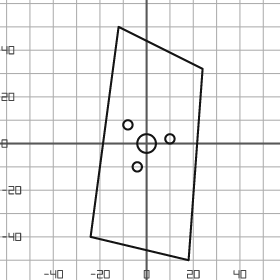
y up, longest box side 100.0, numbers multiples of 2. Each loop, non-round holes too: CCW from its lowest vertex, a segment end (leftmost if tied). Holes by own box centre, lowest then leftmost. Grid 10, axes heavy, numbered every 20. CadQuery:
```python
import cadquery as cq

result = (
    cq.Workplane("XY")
    .moveTo(18.0, -50.0)
    .lineTo(24.0, 32.0)
    .lineTo(-12.0, 50.0)
    .lineTo(-24.0, -40.0)
    .close()
    .moveTo(-4.0, -10.0)
    .circle(2.0)
    .moveTo(0.0, 0.0)
    .circle(4.0)
    .moveTo(10.0, 2.0)
    .circle(2.0)
    .moveTo(-8.0, 8.0)
    .circle(2.0)
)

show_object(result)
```